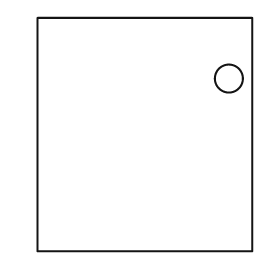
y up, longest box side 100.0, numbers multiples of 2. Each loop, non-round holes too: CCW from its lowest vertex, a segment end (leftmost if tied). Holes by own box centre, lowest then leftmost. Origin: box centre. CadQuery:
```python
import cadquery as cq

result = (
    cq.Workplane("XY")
    .moveTo(-46.0, -50.0)
    .lineTo(46.0, -50.0)
    .lineTo(46.0, 50.0)
    .lineTo(-46.0, 50.0)
    .close()
    .moveTo(36.0, 24.0)
    .circle(6.0)
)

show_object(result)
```